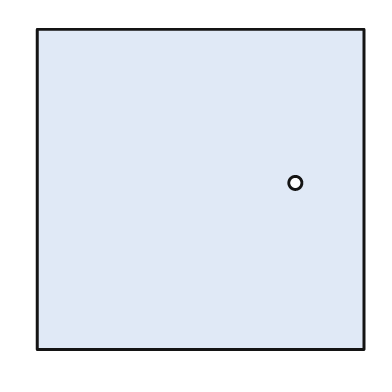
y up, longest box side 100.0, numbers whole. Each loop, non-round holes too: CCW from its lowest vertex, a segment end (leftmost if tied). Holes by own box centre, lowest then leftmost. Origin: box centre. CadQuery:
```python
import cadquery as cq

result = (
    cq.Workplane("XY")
    .moveTo(-50.0, -49.0)
    .lineTo(50.0, -49.0)
    .lineTo(50.0, 49.0)
    .lineTo(-50.0, 49.0)
    .close()
    .moveTo(29.0, 2.0)
    .circle(2.0)
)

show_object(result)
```